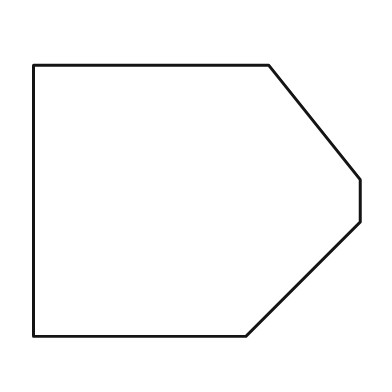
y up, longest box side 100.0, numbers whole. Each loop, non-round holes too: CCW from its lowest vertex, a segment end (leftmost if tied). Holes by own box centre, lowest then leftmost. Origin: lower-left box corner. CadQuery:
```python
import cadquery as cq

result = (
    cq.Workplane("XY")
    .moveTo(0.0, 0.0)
    .lineTo(65.0, 0.0)
    .lineTo(100.0, 35.0)
    .lineTo(100.0, 48.0)
    .lineTo(72.0, 83.0)
    .lineTo(0.0, 83.0)
    .close()
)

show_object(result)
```